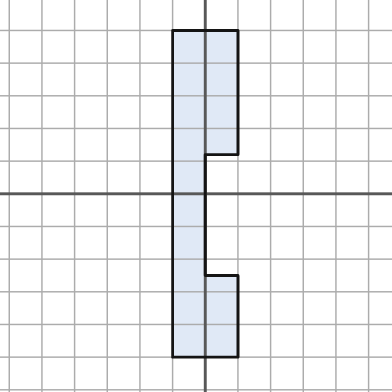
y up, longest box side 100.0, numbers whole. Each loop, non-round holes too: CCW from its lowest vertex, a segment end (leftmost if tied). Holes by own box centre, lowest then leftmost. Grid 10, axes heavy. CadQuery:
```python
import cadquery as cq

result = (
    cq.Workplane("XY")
    .moveTo(-10.0, -50.0)
    .lineTo(10.0, -50.0)
    .lineTo(10.0, -25.0)
    .lineTo(0.0, -25.0)
    .lineTo(0.0, 12.0)
    .lineTo(10.0, 12.0)
    .lineTo(10.0, 50.0)
    .lineTo(-10.0, 50.0)
    .close()
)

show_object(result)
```